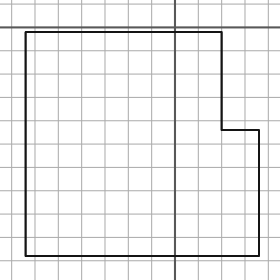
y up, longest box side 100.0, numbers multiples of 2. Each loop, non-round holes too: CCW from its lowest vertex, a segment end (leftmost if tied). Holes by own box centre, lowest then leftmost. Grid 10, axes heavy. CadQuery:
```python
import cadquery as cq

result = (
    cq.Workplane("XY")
    .moveTo(-64.0, -98.0)
    .lineTo(36.0, -98.0)
    .lineTo(36.0, -44.0)
    .lineTo(20.0, -44.0)
    .lineTo(20.0, -2.0)
    .lineTo(-64.0, -2.0)
    .close()
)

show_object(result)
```